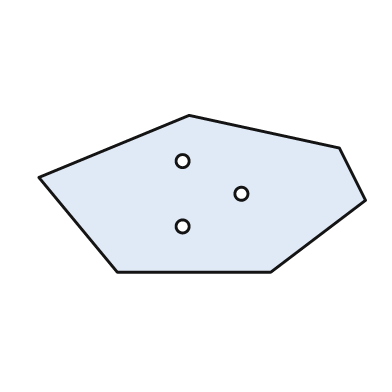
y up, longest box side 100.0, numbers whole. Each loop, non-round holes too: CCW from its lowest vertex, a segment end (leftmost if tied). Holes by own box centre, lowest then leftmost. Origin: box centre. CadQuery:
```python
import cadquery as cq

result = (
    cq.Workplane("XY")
    .moveTo(-26.0, -24.0)
    .lineTo(21.0, -24.0)
    .lineTo(50.0, -2.0)
    .lineTo(42.0, 14.0)
    .lineTo(-4.0, 24.0)
    .lineTo(-50.0, 5.0)
    .close()
    .moveTo(-6.0, -10.0)
    .circle(2.0)
    .moveTo(12.0, 0.0)
    .circle(2.0)
    .moveTo(-6.0, 10.0)
    .circle(2.0)
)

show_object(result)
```